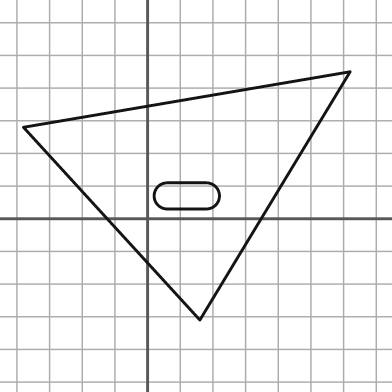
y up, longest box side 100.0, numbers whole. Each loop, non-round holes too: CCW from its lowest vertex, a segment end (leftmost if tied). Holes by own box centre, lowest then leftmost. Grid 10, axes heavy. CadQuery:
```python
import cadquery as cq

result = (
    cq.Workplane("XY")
    .moveTo(16.0, -31.0)
    .lineTo(62.0, 45.0)
    .lineTo(-38.0, 28.0)
    .close()
    .moveTo(6.0, 3.0)
    .lineTo(18.0, 3.0)
    .threePointArc((22.0, 7.0), (18.0, 11.0))
    .lineTo(6.0, 11.0)
    .threePointArc((2.0, 7.0), (6.0, 3.0))
    .close()
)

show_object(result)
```